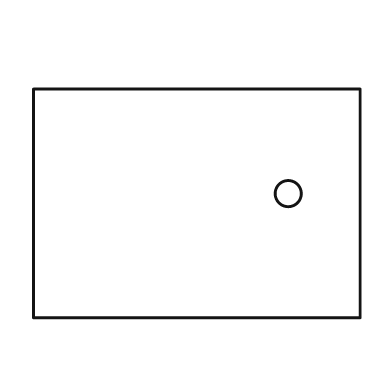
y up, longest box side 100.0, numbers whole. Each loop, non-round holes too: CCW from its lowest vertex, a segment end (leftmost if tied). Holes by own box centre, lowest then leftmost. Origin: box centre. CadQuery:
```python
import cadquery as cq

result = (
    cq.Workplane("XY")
    .moveTo(-50.0, -35.0)
    .lineTo(50.0, -35.0)
    .lineTo(50.0, 35.0)
    .lineTo(-50.0, 35.0)
    .close()
    .moveTo(28.0, 3.0)
    .circle(4.0)
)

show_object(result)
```